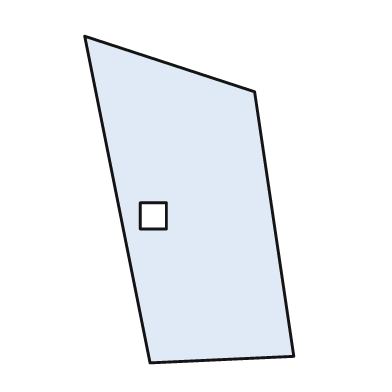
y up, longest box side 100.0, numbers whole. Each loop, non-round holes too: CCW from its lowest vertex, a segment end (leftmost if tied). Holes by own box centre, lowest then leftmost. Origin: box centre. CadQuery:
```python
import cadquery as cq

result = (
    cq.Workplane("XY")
    .moveTo(-12.0, -50.0)
    .lineTo(32.0, -48.0)
    .lineTo(20.0, 33.0)
    .lineTo(-32.0, 50.0)
    .close()
    .moveTo(-15.0, -9.0)
    .lineTo(-7.0, -9.0)
    .lineTo(-7.0, -1.0)
    .lineTo(-15.0, -1.0)
    .close()
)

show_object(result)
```